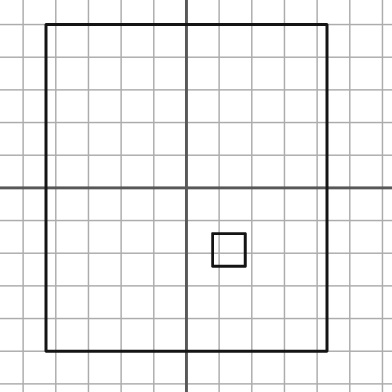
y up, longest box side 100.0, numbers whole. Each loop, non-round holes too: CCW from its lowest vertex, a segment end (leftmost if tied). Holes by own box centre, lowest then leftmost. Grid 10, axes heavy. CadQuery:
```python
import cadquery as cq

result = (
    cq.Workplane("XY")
    .moveTo(-43.0, -50.0)
    .lineTo(43.0, -50.0)
    .lineTo(43.0, 50.0)
    .lineTo(-43.0, 50.0)
    .close()
    .moveTo(8.0, -24.0)
    .lineTo(18.0, -24.0)
    .lineTo(18.0, -14.0)
    .lineTo(8.0, -14.0)
    .close()
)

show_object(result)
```